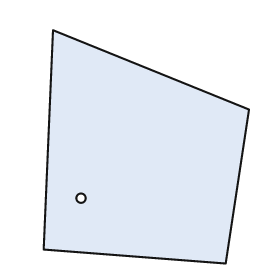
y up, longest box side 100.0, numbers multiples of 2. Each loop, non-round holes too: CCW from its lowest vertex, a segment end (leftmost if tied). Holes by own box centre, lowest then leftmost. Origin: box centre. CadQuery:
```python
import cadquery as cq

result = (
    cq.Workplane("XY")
    .moveTo(34.0, -50.0)
    .lineTo(44.0, 16.0)
    .lineTo(-40.0, 50.0)
    .lineTo(-44.0, -44.0)
    .close()
    .moveTo(-28.0, -22.0)
    .circle(2.0)
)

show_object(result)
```